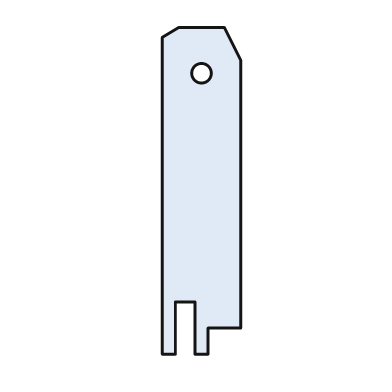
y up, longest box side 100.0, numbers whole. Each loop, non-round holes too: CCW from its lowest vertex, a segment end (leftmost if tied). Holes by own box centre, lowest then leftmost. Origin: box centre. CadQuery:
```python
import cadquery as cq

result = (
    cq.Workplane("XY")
    .moveTo(-12.0, -50.0)
    .lineTo(-8.0, -50.0)
    .lineTo(-8.0, -34.0)
    .lineTo(-2.0, -34.0)
    .lineTo(-2.0, -50.0)
    .lineTo(2.0, -50.0)
    .lineTo(2.0, -42.0)
    .lineTo(12.0, -42.0)
    .lineTo(12.0, 40.0)
    .lineTo(7.0, 50.0)
    .lineTo(-7.0, 50.0)
    .lineTo(-12.0, 47.0)
    .close()
    .moveTo(0.0, 36.0)
    .circle(3.0)
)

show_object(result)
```